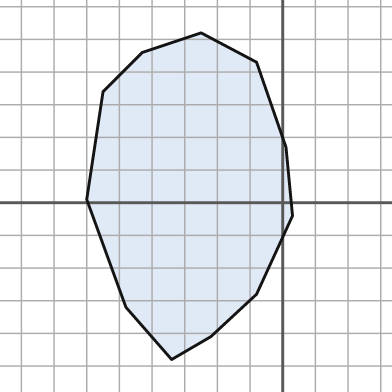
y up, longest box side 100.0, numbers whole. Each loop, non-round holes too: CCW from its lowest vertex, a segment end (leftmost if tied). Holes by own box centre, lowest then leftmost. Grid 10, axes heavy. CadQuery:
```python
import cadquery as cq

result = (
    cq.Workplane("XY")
    .moveTo(-34.0, -48.0)
    .lineTo(-22.0, -41.0)
    .lineTo(-8.0, -28.0)
    .lineTo(3.0, -4.0)
    .lineTo(1.0, 17.0)
    .lineTo(-8.0, 43.0)
    .lineTo(-25.0, 52.0)
    .lineTo(-43.0, 46.0)
    .lineTo(-55.0, 34.0)
    .lineTo(-60.0, 1.0)
    .lineTo(-48.0, -32.0)
    .close()
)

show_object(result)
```